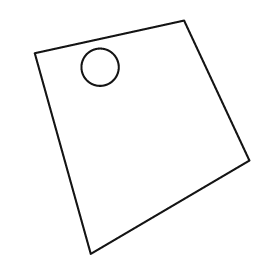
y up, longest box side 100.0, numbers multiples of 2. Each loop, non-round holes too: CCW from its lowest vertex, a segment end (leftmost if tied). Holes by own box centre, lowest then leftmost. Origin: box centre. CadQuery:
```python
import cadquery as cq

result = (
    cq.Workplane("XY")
    .moveTo(-22.0, -50.0)
    .lineTo(46.0, -10.0)
    .lineTo(18.0, 50.0)
    .lineTo(-46.0, 36.0)
    .close()
    .moveTo(-18.0, 30.0)
    .circle(8.0)
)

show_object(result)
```